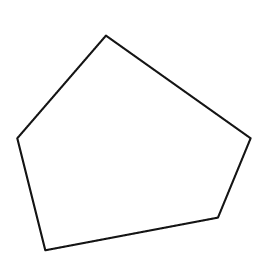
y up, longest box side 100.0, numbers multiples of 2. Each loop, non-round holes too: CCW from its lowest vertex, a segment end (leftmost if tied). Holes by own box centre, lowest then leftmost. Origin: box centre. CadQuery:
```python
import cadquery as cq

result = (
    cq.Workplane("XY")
    .moveTo(-38.0, -46.0)
    .lineTo(36.0, -32.0)
    .lineTo(50.0, 2.0)
    .lineTo(-12.0, 46.0)
    .lineTo(-50.0, 2.0)
    .close()
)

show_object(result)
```